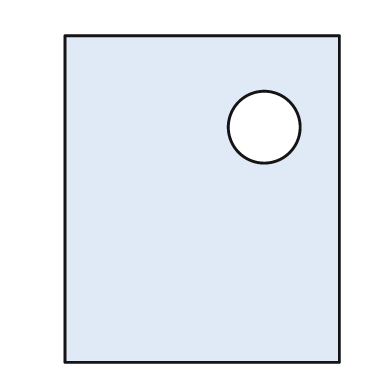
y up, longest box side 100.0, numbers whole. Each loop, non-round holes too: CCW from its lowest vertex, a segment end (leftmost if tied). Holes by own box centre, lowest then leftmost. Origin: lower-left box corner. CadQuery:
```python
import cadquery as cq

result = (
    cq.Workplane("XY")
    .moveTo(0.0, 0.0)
    .lineTo(84.0, 0.0)
    .lineTo(84.0, 100.0)
    .lineTo(0.0, 100.0)
    .close()
    .moveTo(61.0, 72.0)
    .circle(11.0)
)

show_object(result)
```